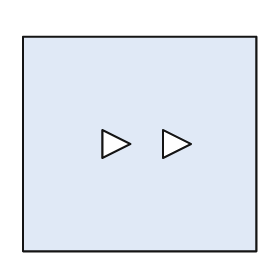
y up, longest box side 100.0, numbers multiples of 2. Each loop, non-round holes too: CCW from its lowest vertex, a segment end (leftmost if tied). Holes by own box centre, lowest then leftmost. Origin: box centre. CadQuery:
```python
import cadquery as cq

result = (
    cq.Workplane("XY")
    .moveTo(-50.0, -46.0)
    .lineTo(50.0, -46.0)
    .lineTo(50.0, 46.0)
    .lineTo(-50.0, 46.0)
    .close()
    .moveTo(-16.0, -6.0)
    .lineTo(-4.0, 0.0)
    .lineTo(-16.0, 6.0)
    .close()
    .moveTo(10.0, -6.0)
    .lineTo(22.0, 0.0)
    .lineTo(10.0, 6.0)
    .close()
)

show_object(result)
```